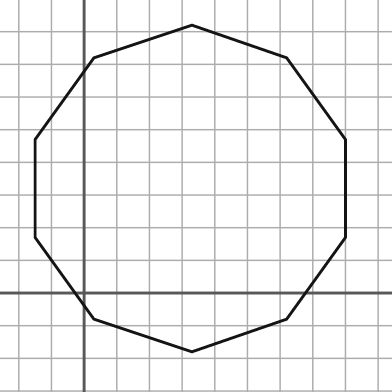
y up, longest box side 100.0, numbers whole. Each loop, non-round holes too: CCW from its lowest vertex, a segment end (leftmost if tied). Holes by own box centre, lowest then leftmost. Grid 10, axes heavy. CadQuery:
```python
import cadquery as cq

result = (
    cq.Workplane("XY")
    .moveTo(33.0, -18.0)
    .lineTo(62.0, -8.0)
    .lineTo(80.0, 17.0)
    .lineTo(80.0, 47.0)
    .lineTo(62.0, 72.0)
    .lineTo(33.0, 82.0)
    .lineTo(3.0, 72.0)
    .lineTo(-15.0, 47.0)
    .lineTo(-15.0, 17.0)
    .lineTo(3.0, -8.0)
    .close()
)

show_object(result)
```